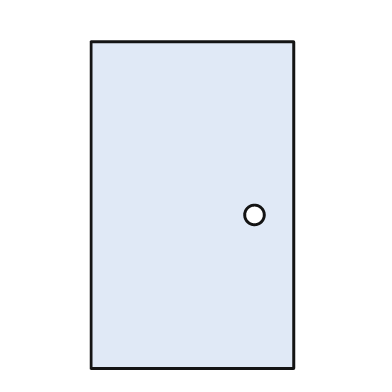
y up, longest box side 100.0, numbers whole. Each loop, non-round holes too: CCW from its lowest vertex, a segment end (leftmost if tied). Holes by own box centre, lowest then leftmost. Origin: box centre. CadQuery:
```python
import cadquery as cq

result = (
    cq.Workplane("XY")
    .moveTo(-31.0, -50.0)
    .lineTo(31.0, -50.0)
    .lineTo(31.0, 50.0)
    .lineTo(-31.0, 50.0)
    .close()
    .moveTo(19.0, -3.0)
    .circle(3.0)
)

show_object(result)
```